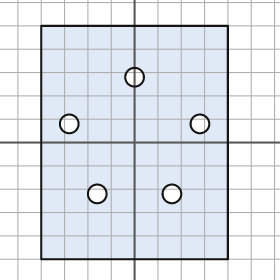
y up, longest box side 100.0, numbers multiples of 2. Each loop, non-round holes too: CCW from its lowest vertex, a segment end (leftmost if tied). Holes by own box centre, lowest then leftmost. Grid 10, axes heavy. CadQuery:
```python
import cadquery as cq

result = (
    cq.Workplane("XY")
    .moveTo(-40.0, -50.0)
    .lineTo(40.0, -50.0)
    .lineTo(40.0, 50.0)
    .lineTo(-40.0, 50.0)
    .close()
    .moveTo(-16.0, -22.0)
    .circle(4.0)
    .moveTo(16.0, -22.0)
    .circle(4.0)
    .moveTo(-28.0, 8.0)
    .circle(4.0)
    .moveTo(28.0, 8.0)
    .circle(4.0)
    .moveTo(0.0, 28.0)
    .circle(4.0)
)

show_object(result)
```